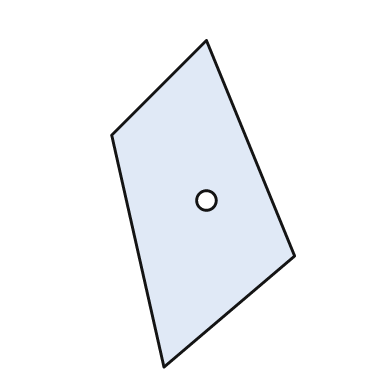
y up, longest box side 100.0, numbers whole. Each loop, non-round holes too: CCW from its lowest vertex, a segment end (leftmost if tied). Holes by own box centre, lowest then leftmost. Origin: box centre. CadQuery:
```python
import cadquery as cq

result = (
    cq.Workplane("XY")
    .moveTo(-12.0, -50.0)
    .lineTo(28.0, -16.0)
    .lineTo(1.0, 50.0)
    .lineTo(-28.0, 21.0)
    .close()
    .moveTo(1.0, 1.0)
    .circle(3.0)
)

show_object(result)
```